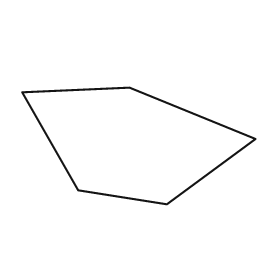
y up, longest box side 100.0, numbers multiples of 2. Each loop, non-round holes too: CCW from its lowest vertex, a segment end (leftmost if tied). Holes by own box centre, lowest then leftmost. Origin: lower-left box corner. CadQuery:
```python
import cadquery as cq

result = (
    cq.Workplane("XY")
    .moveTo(62.0, 0.0)
    .lineTo(100.0, 28.0)
    .lineTo(46.0, 50.0)
    .lineTo(0.0, 48.0)
    .lineTo(24.0, 6.0)
    .close()
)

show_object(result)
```